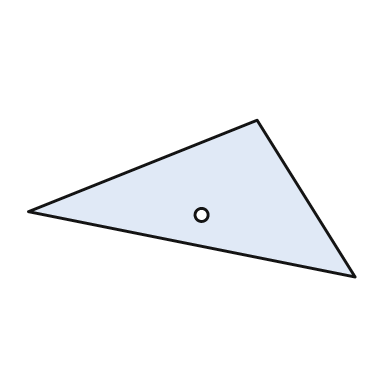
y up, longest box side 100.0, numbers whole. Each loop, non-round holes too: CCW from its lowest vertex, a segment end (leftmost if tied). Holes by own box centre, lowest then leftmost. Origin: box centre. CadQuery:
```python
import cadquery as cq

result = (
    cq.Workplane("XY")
    .moveTo(50.0, -24.0)
    .lineTo(20.0, 24.0)
    .lineTo(-50.0, -4.0)
    .close()
    .moveTo(3.0, -5.0)
    .circle(2.0)
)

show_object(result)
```